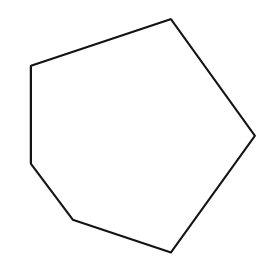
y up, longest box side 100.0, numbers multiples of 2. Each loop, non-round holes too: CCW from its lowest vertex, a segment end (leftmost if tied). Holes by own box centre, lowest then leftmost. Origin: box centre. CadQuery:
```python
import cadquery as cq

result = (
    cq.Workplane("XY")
    .moveTo(12.0, -50.0)
    .lineTo(48.0, 0.0)
    .lineTo(12.0, 50.0)
    .lineTo(-48.0, 30.0)
    .lineTo(-48.0, -12.0)
    .lineTo(-30.0, -36.0)
    .close()
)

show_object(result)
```